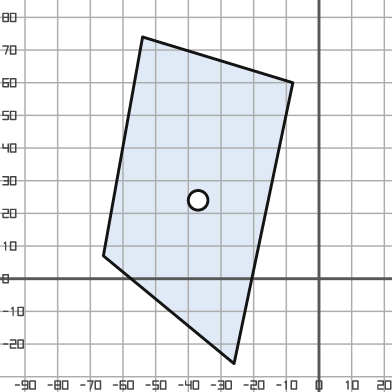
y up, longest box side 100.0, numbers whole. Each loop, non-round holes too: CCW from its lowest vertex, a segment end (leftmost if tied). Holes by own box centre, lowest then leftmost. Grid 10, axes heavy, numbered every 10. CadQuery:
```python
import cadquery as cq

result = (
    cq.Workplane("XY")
    .moveTo(-26.0, -26.0)
    .lineTo(-8.0, 60.0)
    .lineTo(-54.0, 74.0)
    .lineTo(-66.0, 7.0)
    .close()
    .moveTo(-37.0, 24.0)
    .circle(3.0)
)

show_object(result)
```